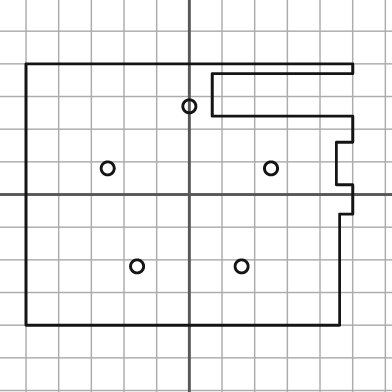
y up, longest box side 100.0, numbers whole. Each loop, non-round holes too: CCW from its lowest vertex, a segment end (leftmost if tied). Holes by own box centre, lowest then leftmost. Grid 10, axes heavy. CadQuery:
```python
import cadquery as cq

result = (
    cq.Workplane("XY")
    .moveTo(-50.0, -40.0)
    .lineTo(46.0, -40.0)
    .lineTo(46.0, -6.0)
    .lineTo(50.0, -6.0)
    .lineTo(50.0, 3.0)
    .lineTo(45.0, 3.0)
    .lineTo(45.0, 16.0)
    .lineTo(50.0, 16.0)
    .lineTo(50.0, 24.0)
    .lineTo(7.0, 24.0)
    .lineTo(7.0, 37.0)
    .lineTo(50.0, 37.0)
    .lineTo(50.0, 40.0)
    .lineTo(-50.0, 40.0)
    .close()
    .moveTo(-16.0, -22.0)
    .circle(2.0)
    .moveTo(16.0, -22.0)
    .circle(2.0)
    .moveTo(-25.0, 8.0)
    .circle(2.0)
    .moveTo(25.0, 8.0)
    .circle(2.0)
    .moveTo(0.0, 27.0)
    .circle(2.0)
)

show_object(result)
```